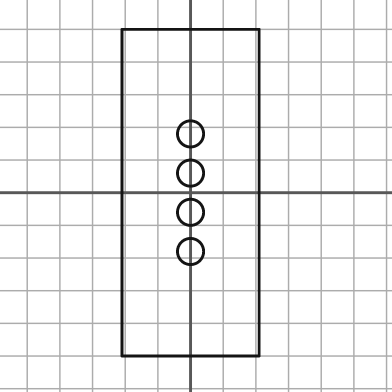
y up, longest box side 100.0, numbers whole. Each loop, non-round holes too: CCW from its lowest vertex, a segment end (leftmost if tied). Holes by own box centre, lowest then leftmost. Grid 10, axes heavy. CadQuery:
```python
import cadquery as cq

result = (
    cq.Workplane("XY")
    .moveTo(-21.0, -50.0)
    .lineTo(21.0, -50.0)
    .lineTo(21.0, 50.0)
    .lineTo(-21.0, 50.0)
    .close()
    .moveTo(0.0, -18.0)
    .circle(4.0)
    .moveTo(0.0, -6.0)
    .circle(4.0)
    .moveTo(0.0, 6.0)
    .circle(4.0)
    .moveTo(0.0, 18.0)
    .circle(4.0)
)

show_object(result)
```